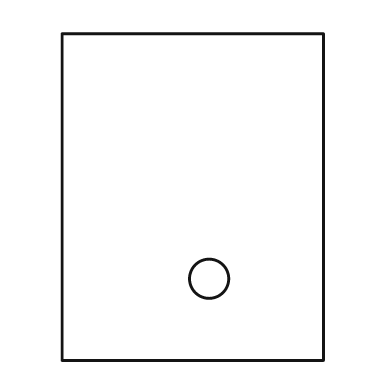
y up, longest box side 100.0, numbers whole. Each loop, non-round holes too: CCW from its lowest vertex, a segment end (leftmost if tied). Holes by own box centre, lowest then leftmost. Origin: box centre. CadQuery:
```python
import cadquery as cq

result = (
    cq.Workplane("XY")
    .moveTo(-40.0, -50.0)
    .lineTo(40.0, -50.0)
    .lineTo(40.0, 50.0)
    .lineTo(-40.0, 50.0)
    .close()
    .moveTo(5.0, -25.0)
    .circle(6.0)
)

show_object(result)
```